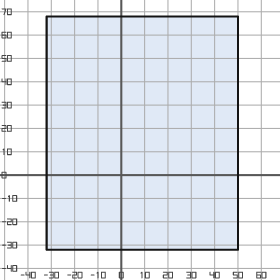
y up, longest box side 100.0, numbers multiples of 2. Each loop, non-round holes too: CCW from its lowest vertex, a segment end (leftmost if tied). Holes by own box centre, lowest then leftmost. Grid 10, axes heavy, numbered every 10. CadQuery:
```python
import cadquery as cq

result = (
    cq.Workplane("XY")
    .moveTo(-32.0, -32.0)
    .lineTo(50.0, -32.0)
    .lineTo(50.0, 68.0)
    .lineTo(-32.0, 68.0)
    .close()
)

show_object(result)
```